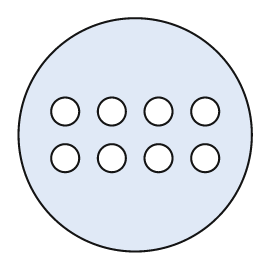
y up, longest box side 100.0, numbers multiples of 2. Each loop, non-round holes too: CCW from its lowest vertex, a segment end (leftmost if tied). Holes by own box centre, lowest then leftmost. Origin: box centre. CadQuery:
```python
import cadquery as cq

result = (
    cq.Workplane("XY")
    .moveTo(0.0, 0.0)
    .circle(50.0)
    .moveTo(-30.0, -10.0)
    .circle(6.0)
    .moveTo(-10.0, -10.0)
    .circle(6.0)
    .moveTo(10.0, -10.0)
    .circle(6.0)
    .moveTo(30.0, -10.0)
    .circle(6.0)
    .moveTo(-30.0, 10.0)
    .circle(6.0)
    .moveTo(-10.0, 10.0)
    .circle(6.0)
    .moveTo(10.0, 10.0)
    .circle(6.0)
    .moveTo(30.0, 10.0)
    .circle(6.0)
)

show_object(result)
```